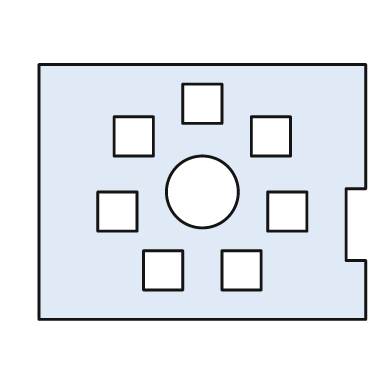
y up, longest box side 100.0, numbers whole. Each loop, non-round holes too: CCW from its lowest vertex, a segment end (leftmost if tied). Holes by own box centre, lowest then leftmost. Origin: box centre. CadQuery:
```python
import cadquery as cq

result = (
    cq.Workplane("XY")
    .moveTo(-50.0, -39.0)
    .lineTo(50.0, -39.0)
    .lineTo(50.0, -21.0)
    .lineTo(44.0, -21.0)
    .lineTo(44.0, 1.0)
    .lineTo(50.0, 1.0)
    .lineTo(50.0, 39.0)
    .lineTo(-50.0, 39.0)
    .close()
    .moveTo(-18.0, -30.0)
    .lineTo(-6.0, -30.0)
    .lineTo(-6.0, -18.0)
    .lineTo(-18.0, -18.0)
    .close()
    .moveTo(6.0, -30.0)
    .lineTo(18.0, -30.0)
    .lineTo(18.0, -18.0)
    .lineTo(6.0, -18.0)
    .close()
    .moveTo(-32.0, -12.0)
    .lineTo(-20.0, -12.0)
    .lineTo(-20.0, 0.0)
    .lineTo(-32.0, 0.0)
    .close()
    .moveTo(20.0, -12.0)
    .lineTo(32.0, -12.0)
    .lineTo(32.0, 0.0)
    .lineTo(20.0, 0.0)
    .close()
    .moveTo(0.0, 0.0)
    .circle(11.0)
    .moveTo(-27.0, 11.0)
    .lineTo(-15.0, 11.0)
    .lineTo(-15.0, 23.0)
    .lineTo(-27.0, 23.0)
    .close()
    .moveTo(15.0, 11.0)
    .lineTo(27.0, 11.0)
    .lineTo(27.0, 23.0)
    .lineTo(15.0, 23.0)
    .close()
    .moveTo(-6.0, 21.0)
    .lineTo(6.0, 21.0)
    .lineTo(6.0, 33.0)
    .lineTo(-6.0, 33.0)
    .close()
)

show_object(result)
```